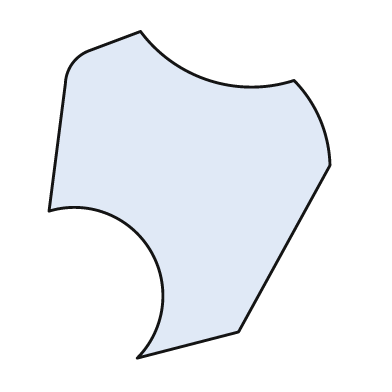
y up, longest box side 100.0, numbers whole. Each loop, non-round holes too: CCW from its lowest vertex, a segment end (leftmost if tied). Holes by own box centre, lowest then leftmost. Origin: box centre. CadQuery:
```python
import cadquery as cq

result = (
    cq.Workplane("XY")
    .moveTo(-16.0, -50.0)
    .lineTo(15.0, -42.0)
    .lineTo(43.0, 9.0)
    .threePointArc((40.0, 23.0), (32.0, 35.0))
    .threePointArc((6.0, 35.0), (-15.0, 50.0))
    .lineTo(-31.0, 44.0)
    .threePointArc((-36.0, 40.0), (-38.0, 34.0))
    .lineTo(-43.0, -5.0)
    .threePointArc((-12.0, -17.0), (-16.0, -50.0))
    .close()
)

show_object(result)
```